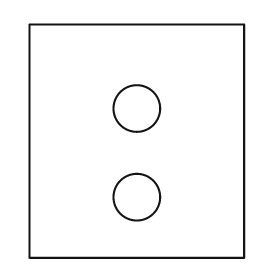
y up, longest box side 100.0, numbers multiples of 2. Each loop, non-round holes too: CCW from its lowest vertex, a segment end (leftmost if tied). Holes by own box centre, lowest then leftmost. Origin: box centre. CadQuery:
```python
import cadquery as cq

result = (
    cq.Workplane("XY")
    .moveTo(-46.0, -50.0)
    .lineTo(46.0, -50.0)
    .lineTo(46.0, 50.0)
    .lineTo(-46.0, 50.0)
    .close()
    .moveTo(0.0, -24.0)
    .circle(10.0)
    .moveTo(0.0, 14.0)
    .circle(10.0)
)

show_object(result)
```